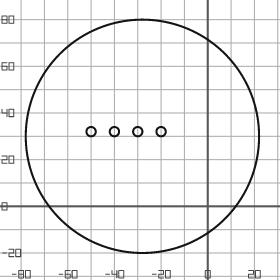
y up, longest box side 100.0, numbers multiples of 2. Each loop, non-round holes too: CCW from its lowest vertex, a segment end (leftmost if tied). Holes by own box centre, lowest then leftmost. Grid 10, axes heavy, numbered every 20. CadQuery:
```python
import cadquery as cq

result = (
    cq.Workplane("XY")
    .moveTo(-28.0, 30.0)
    .circle(50.0)
    .moveTo(-50.0, 32.0)
    .circle(2.0)
    .moveTo(-40.0, 32.0)
    .circle(2.0)
    .moveTo(-30.0, 32.0)
    .circle(2.0)
    .moveTo(-20.0, 32.0)
    .circle(2.0)
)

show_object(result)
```